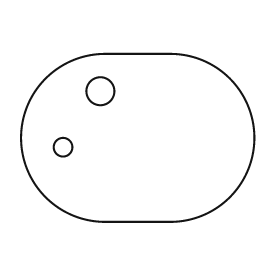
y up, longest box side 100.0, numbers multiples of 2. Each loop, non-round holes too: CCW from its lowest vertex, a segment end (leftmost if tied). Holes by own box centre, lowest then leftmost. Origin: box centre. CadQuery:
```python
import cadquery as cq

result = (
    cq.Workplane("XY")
    .moveTo(-14.0, -36.0)
    .lineTo(14.0, -36.0)
    .threePointArc((50.0, 0.0), (14.0, 36.0))
    .lineTo(-14.0, 36.0)
    .threePointArc((-50.0, 0.0), (-14.0, -36.0))
    .close()
    .moveTo(-32.0, -4.0)
    .circle(4.0)
    .moveTo(-16.0, 20.0)
    .circle(6.0)
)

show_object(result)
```